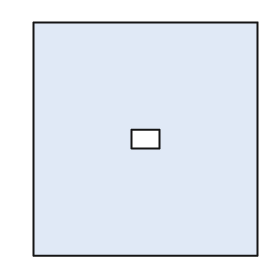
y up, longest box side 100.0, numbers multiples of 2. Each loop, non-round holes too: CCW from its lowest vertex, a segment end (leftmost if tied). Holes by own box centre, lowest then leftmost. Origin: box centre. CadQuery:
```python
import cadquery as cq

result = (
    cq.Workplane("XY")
    .moveTo(-48.0, -50.0)
    .lineTo(48.0, -50.0)
    .lineTo(48.0, 50.0)
    .lineTo(-48.0, 50.0)
    .close()
    .moveTo(-6.0, -4.0)
    .lineTo(6.0, -4.0)
    .lineTo(6.0, 4.0)
    .lineTo(-6.0, 4.0)
    .close()
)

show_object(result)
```